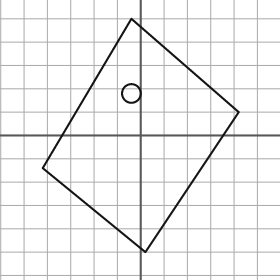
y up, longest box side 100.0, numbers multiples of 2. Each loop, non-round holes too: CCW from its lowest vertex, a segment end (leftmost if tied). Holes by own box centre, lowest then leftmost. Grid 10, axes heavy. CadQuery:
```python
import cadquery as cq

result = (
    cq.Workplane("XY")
    .moveTo(2.0, -50.0)
    .lineTo(42.0, 10.0)
    .lineTo(-4.0, 50.0)
    .lineTo(-42.0, -14.0)
    .close()
    .moveTo(-4.0, 18.0)
    .circle(4.0)
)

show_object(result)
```